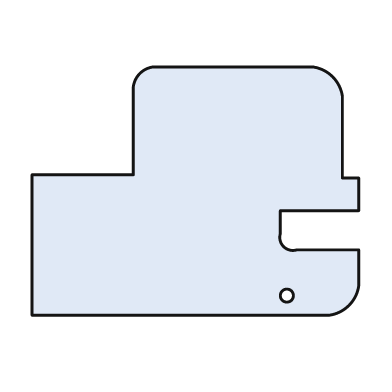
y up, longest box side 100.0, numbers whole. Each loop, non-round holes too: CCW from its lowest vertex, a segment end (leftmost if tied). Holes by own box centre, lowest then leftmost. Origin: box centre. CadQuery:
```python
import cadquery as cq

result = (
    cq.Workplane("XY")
    .moveTo(-50.0, -38.0)
    .lineTo(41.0, -38.0)
    .threePointArc((47.0, -35.0), (50.0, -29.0))
    .lineTo(50.0, -18.0)
    .lineTo(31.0, -18.0)
    .threePointArc((27.0, -17.0), (26.0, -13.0))
    .lineTo(26.0, -6.0)
    .lineTo(50.0, -6.0)
    .lineTo(50.0, 4.0)
    .lineTo(45.0, 4.0)
    .lineTo(45.0, 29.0)
    .threePointArc((42.0, 35.0), (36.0, 38.0))
    .lineTo(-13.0, 38.0)
    .threePointArc((-17.0, 36.0), (-19.0, 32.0))
    .lineTo(-19.0, 5.0)
    .lineTo(-50.0, 5.0)
    .close()
    .moveTo(28.0, -32.0)
    .circle(2.0)
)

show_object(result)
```